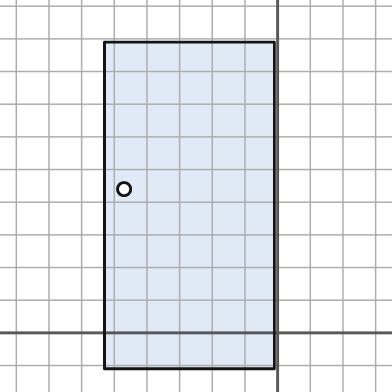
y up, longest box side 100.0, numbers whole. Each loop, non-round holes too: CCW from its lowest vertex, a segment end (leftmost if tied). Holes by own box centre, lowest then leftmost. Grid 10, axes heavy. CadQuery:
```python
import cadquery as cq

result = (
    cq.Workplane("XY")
    .moveTo(-53.0, -11.0)
    .lineTo(-1.0, -11.0)
    .lineTo(-1.0, 89.0)
    .lineTo(-53.0, 89.0)
    .close()
    .moveTo(-47.0, 44.0)
    .circle(2.0)
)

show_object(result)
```